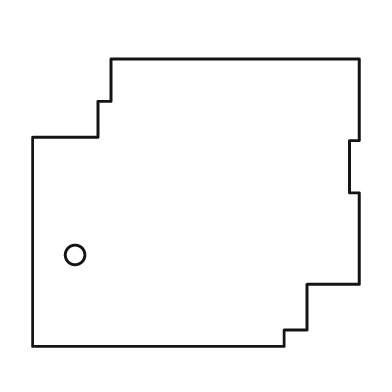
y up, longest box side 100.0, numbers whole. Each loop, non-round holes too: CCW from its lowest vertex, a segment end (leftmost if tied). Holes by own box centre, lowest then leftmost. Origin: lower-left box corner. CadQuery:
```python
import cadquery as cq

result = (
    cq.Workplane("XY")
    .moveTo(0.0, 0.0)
    .lineTo(77.0, 0.0)
    .lineTo(77.0, 5.0)
    .lineTo(84.0, 5.0)
    .lineTo(84.0, 19.0)
    .lineTo(100.0, 19.0)
    .lineTo(100.0, 47.0)
    .lineTo(97.0, 47.0)
    .lineTo(97.0, 63.0)
    .lineTo(100.0, 63.0)
    .lineTo(100.0, 88.0)
    .lineTo(24.0, 88.0)
    .lineTo(24.0, 75.0)
    .lineTo(20.0, 75.0)
    .lineTo(20.0, 64.0)
    .lineTo(0.0, 64.0)
    .close()
    .moveTo(13.0, 28.0)
    .circle(3.0)
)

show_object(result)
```